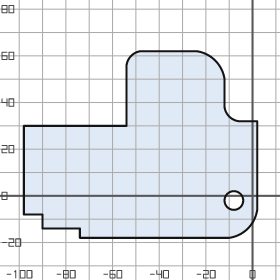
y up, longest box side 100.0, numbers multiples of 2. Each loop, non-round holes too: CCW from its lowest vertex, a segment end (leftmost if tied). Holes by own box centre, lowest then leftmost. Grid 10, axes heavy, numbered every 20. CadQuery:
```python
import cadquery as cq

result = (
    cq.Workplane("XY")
    .moveTo(-74.0, -18.0)
    .lineTo(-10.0, -18.0)
    .threePointArc((-2.0, -14.0), (2.0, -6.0))
    .lineTo(2.0, 32.0)
    .lineTo(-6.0, 32.0)
    .threePointArc((-10.0, 34.0), (-12.0, 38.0))
    .lineTo(-12.0, 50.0)
    .threePointArc((-16.0, 58.0), (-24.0, 62.0))
    .lineTo(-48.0, 62.0)
    .threePointArc((-52.0, 60.0), (-54.0, 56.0))
    .lineTo(-54.0, 30.0)
    .lineTo(-98.0, 30.0)
    .lineTo(-98.0, -8.0)
    .lineTo(-90.0, -8.0)
    .lineTo(-90.0, -14.0)
    .lineTo(-74.0, -14.0)
    .close()
    .moveTo(-8.0, -2.0)
    .circle(4.0)
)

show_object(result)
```